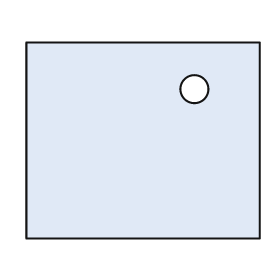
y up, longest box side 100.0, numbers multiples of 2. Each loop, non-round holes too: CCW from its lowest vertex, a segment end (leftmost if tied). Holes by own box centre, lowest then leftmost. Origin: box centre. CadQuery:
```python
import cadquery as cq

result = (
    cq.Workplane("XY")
    .moveTo(-50.0, -42.0)
    .lineTo(50.0, -42.0)
    .lineTo(50.0, 42.0)
    .lineTo(-50.0, 42.0)
    .close()
    .moveTo(22.0, 22.0)
    .circle(6.0)
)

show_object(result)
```